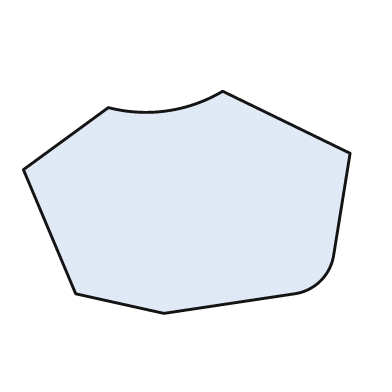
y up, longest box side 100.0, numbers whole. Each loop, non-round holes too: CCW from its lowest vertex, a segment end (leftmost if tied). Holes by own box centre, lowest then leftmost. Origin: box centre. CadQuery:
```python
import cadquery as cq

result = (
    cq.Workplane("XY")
    .moveTo(-7.0, -34.0)
    .lineTo(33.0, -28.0)
    .threePointArc((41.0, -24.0), (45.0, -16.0))
    .lineTo(50.0, 15.0)
    .lineTo(11.0, 34.0)
    .threePointArc((-6.0, 28.0), (-24.0, 29.0))
    .lineTo(-50.0, 10.0)
    .lineTo(-34.0, -28.0)
    .close()
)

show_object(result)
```